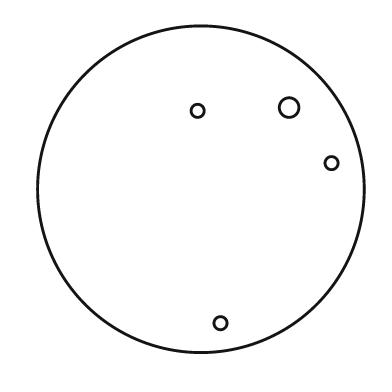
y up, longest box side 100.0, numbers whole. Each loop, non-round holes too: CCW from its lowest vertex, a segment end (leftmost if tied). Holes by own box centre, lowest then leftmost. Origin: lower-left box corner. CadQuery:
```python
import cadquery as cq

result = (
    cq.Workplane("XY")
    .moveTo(50.0, 50.0)
    .circle(50.0)
    .moveTo(56.0, 9.0)
    .circle(2.0)
    .moveTo(90.0, 58.0)
    .circle(2.0)
    .moveTo(49.0, 74.0)
    .circle(2.0)
    .moveTo(77.0, 75.0)
    .circle(3.0)
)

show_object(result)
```